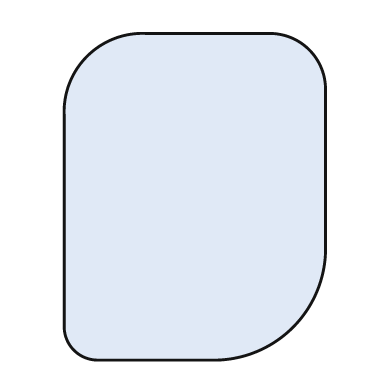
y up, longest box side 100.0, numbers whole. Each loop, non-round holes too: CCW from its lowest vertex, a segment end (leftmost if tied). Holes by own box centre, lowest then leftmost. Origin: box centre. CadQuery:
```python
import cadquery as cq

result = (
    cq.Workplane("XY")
    .moveTo(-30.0, -50.0)
    .lineTo(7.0, -50.0)
    .threePointArc((30.0, -40.0), (40.0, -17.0))
    .lineTo(40.0, 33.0)
    .threePointArc((35.0, 45.0), (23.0, 50.0))
    .lineTo(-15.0, 50.0)
    .threePointArc((-33.0, 43.0), (-40.0, 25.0))
    .lineTo(-40.0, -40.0)
    .threePointArc((-37.0, -47.0), (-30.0, -50.0))
    .close()
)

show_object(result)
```